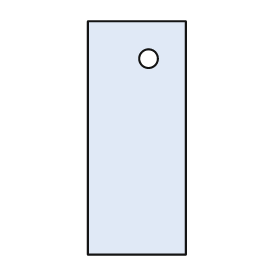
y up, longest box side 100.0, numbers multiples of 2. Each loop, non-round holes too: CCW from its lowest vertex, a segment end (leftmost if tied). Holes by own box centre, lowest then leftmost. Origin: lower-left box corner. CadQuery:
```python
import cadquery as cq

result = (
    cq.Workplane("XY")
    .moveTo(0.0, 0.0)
    .lineTo(42.0, 0.0)
    .lineTo(42.0, 100.0)
    .lineTo(0.0, 100.0)
    .close()
    .moveTo(26.0, 84.0)
    .circle(4.0)
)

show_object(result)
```